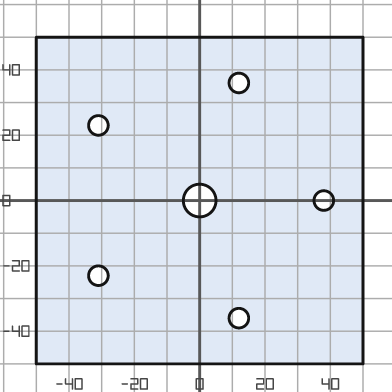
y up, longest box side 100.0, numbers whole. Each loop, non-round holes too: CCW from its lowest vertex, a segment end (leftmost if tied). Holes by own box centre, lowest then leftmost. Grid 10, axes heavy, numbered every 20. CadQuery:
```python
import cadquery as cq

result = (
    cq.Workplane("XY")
    .moveTo(-50.0, -50.0)
    .lineTo(50.0, -50.0)
    .lineTo(50.0, 50.0)
    .lineTo(-50.0, 50.0)
    .close()
    .moveTo(12.0, -36.0)
    .circle(3.0)
    .moveTo(-31.0, -23.0)
    .circle(3.0)
    .moveTo(0.0, 0.0)
    .circle(5.0)
    .moveTo(38.0, 0.0)
    .circle(3.0)
    .moveTo(-31.0, 23.0)
    .circle(3.0)
    .moveTo(12.0, 36.0)
    .circle(3.0)
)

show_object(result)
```